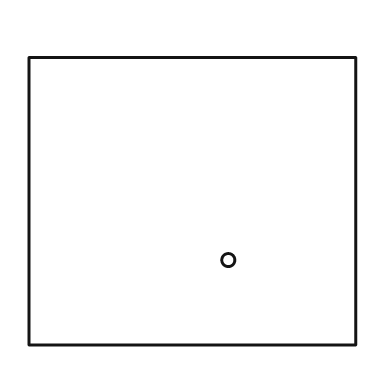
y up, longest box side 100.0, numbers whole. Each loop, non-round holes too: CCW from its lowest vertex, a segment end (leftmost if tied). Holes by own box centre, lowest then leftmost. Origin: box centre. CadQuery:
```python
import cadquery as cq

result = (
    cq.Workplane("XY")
    .moveTo(-50.0, -44.0)
    .lineTo(50.0, -44.0)
    .lineTo(50.0, 44.0)
    .lineTo(-50.0, 44.0)
    .close()
    .moveTo(11.0, -18.0)
    .circle(2.0)
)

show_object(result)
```